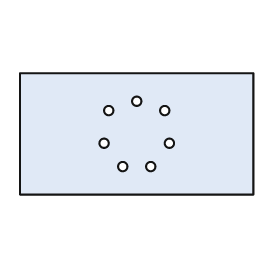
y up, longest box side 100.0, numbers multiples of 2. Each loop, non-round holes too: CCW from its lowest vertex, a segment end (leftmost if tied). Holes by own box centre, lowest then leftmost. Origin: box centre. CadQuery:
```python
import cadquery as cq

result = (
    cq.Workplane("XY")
    .moveTo(-50.0, -26.0)
    .lineTo(50.0, -26.0)
    .lineTo(50.0, 26.0)
    .lineTo(-50.0, 26.0)
    .close()
    .moveTo(-6.0, -14.0)
    .circle(2.0)
    .moveTo(6.0, -14.0)
    .circle(2.0)
    .moveTo(-14.0, -4.0)
    .circle(2.0)
    .moveTo(14.0, -4.0)
    .circle(2.0)
    .moveTo(-12.0, 10.0)
    .circle(2.0)
    .moveTo(12.0, 10.0)
    .circle(2.0)
    .moveTo(0.0, 14.0)
    .circle(2.0)
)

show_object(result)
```